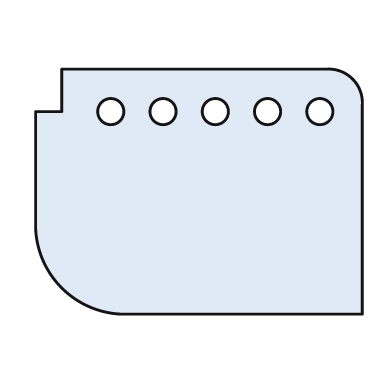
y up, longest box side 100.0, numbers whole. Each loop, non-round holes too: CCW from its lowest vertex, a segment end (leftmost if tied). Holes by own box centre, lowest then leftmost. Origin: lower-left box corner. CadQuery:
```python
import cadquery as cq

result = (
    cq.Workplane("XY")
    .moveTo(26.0, 0.0)
    .lineTo(100.0, 0.0)
    .lineTo(100.0, 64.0)
    .threePointArc((97.0, 72.0), (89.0, 75.0))
    .lineTo(8.0, 75.0)
    .lineTo(8.0, 62.0)
    .lineTo(0.0, 62.0)
    .lineTo(0.0, 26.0)
    .threePointArc((8.0, 8.0), (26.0, 0.0))
    .close()
    .moveTo(23.0, 62.0)
    .circle(4.0)
    .moveTo(39.0, 62.0)
    .circle(4.0)
    .moveTo(55.0, 62.0)
    .circle(4.0)
    .moveTo(71.0, 62.0)
    .circle(4.0)
    .moveTo(87.0, 62.0)
    .circle(4.0)
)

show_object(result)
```